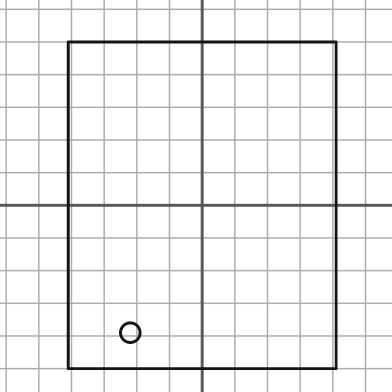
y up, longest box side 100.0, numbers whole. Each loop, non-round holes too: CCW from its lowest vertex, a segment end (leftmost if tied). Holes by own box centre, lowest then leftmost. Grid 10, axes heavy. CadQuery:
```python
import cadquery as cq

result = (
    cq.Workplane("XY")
    .moveTo(-41.0, -50.0)
    .lineTo(41.0, -50.0)
    .lineTo(41.0, 50.0)
    .lineTo(-41.0, 50.0)
    .close()
    .moveTo(-22.0, -39.0)
    .circle(3.0)
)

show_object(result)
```